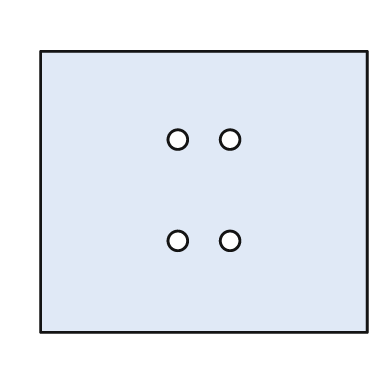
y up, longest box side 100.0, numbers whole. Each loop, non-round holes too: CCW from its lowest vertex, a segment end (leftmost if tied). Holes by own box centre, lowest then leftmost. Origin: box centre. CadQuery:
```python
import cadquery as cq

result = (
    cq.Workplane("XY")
    .moveTo(-50.0, -43.0)
    .lineTo(50.0, -43.0)
    .lineTo(50.0, 43.0)
    .lineTo(-50.0, 43.0)
    .close()
    .moveTo(-8.0, -15.0)
    .circle(3.0)
    .moveTo(8.0, -15.0)
    .circle(3.0)
    .moveTo(-8.0, 16.0)
    .circle(3.0)
    .moveTo(8.0, 16.0)
    .circle(3.0)
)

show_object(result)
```